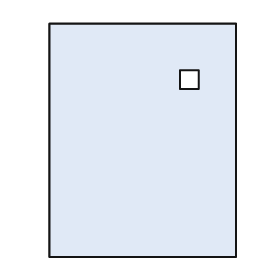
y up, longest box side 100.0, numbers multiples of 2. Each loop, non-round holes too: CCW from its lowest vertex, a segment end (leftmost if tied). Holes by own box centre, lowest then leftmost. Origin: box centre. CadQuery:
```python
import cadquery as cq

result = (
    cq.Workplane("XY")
    .moveTo(-40.0, -50.0)
    .lineTo(40.0, -50.0)
    .lineTo(40.0, 50.0)
    .lineTo(-40.0, 50.0)
    .close()
    .moveTo(16.0, 22.0)
    .lineTo(24.0, 22.0)
    .lineTo(24.0, 30.0)
    .lineTo(16.0, 30.0)
    .close()
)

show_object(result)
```